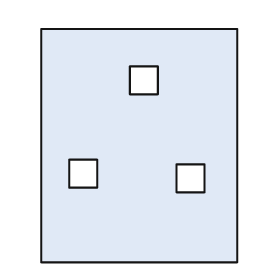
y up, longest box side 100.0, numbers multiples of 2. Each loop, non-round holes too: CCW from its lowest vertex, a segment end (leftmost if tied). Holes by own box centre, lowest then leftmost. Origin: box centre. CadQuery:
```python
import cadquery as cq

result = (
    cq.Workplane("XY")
    .moveTo(-42.0, -50.0)
    .lineTo(42.0, -50.0)
    .lineTo(42.0, 50.0)
    .lineTo(-42.0, 50.0)
    .close()
    .moveTo(16.0, -20.0)
    .lineTo(28.0, -20.0)
    .lineTo(28.0, -8.0)
    .lineTo(16.0, -8.0)
    .close()
    .moveTo(-30.0, -18.0)
    .lineTo(-18.0, -18.0)
    .lineTo(-18.0, -6.0)
    .lineTo(-30.0, -6.0)
    .close()
    .moveTo(-4.0, 22.0)
    .lineTo(8.0, 22.0)
    .lineTo(8.0, 34.0)
    .lineTo(-4.0, 34.0)
    .close()
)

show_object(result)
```